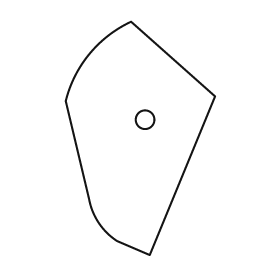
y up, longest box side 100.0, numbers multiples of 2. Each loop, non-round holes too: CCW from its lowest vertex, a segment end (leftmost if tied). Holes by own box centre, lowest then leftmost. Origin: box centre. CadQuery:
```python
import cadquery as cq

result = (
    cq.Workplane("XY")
    .moveTo(4.0, -50.0)
    .lineTo(32.0, 18.0)
    .lineTo(-4.0, 50.0)
    .threePointArc((-22.0, 36.0), (-32.0, 16.0))
    .lineTo(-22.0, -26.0)
    .threePointArc((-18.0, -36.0), (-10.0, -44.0))
    .close()
    .moveTo(2.0, 8.0)
    .circle(4.0)
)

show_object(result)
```